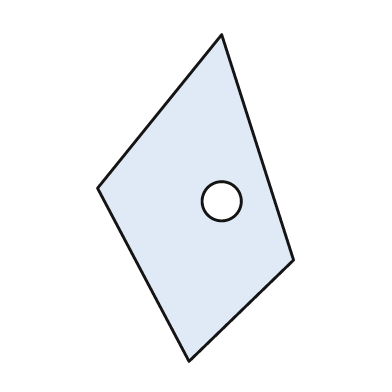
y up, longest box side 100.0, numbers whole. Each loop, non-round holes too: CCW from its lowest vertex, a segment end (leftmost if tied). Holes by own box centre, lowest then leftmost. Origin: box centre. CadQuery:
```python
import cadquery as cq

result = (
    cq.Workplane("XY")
    .moveTo(-2.0, -50.0)
    .lineTo(30.0, -19.0)
    .lineTo(8.0, 50.0)
    .lineTo(-30.0, 3.0)
    .close()
    .moveTo(8.0, -1.0)
    .circle(6.0)
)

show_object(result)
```